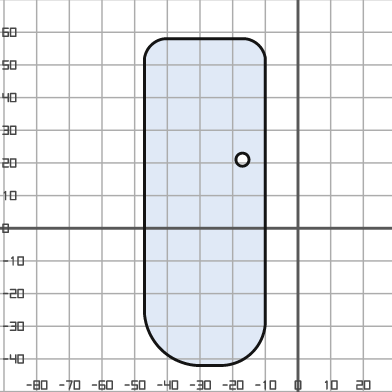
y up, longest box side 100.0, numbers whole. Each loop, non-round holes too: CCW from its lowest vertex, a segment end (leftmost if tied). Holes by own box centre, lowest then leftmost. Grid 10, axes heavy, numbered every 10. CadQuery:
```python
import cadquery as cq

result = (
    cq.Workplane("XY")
    .moveTo(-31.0, -42.0)
    .lineTo(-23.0, -42.0)
    .threePointArc((-14.0, -38.0), (-10.0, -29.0))
    .lineTo(-10.0, 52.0)
    .threePointArc((-12.0, 56.0), (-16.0, 58.0))
    .lineTo(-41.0, 58.0)
    .threePointArc((-45.0, 56.0), (-47.0, 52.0))
    .lineTo(-47.0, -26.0)
    .threePointArc((-42.0, -37.0), (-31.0, -42.0))
    .close()
    .moveTo(-17.0, 21.0)
    .circle(2.0)
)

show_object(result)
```